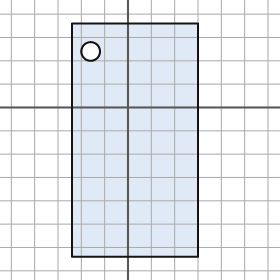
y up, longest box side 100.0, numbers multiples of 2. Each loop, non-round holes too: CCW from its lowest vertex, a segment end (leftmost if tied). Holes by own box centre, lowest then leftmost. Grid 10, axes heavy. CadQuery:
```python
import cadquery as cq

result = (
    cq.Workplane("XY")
    .moveTo(-24.0, -64.0)
    .lineTo(30.0, -64.0)
    .lineTo(30.0, 36.0)
    .lineTo(-24.0, 36.0)
    .close()
    .moveTo(-16.0, 24.0)
    .circle(4.0)
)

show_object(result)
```